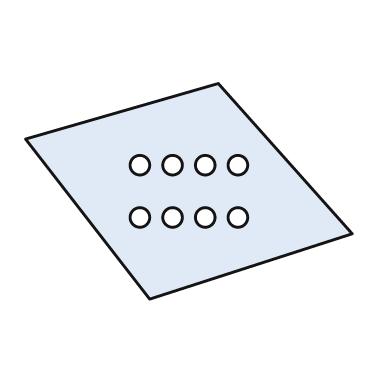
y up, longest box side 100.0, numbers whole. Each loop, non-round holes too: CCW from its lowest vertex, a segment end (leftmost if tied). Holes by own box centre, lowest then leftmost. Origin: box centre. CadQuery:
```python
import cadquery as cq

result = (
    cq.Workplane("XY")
    .moveTo(-12.0, -33.0)
    .lineTo(50.0, -13.0)
    .lineTo(9.0, 33.0)
    .lineTo(-50.0, 16.0)
    .close()
    .moveTo(-15.0, -8.0)
    .circle(3.0)
    .moveTo(-5.0, -8.0)
    .circle(3.0)
    .moveTo(5.0, -8.0)
    .circle(3.0)
    .moveTo(15.0, -8.0)
    .circle(3.0)
    .moveTo(-15.0, 8.0)
    .circle(3.0)
    .moveTo(-5.0, 8.0)
    .circle(3.0)
    .moveTo(5.0, 8.0)
    .circle(3.0)
    .moveTo(15.0, 8.0)
    .circle(3.0)
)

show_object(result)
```